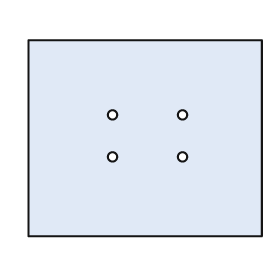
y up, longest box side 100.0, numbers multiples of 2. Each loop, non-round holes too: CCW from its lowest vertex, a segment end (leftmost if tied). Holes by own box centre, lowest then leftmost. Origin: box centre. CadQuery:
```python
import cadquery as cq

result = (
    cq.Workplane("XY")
    .moveTo(-50.0, -42.0)
    .lineTo(50.0, -42.0)
    .lineTo(50.0, 42.0)
    .lineTo(-50.0, 42.0)
    .close()
    .moveTo(-14.0, -8.0)
    .circle(2.0)
    .moveTo(16.0, -8.0)
    .circle(2.0)
    .moveTo(-14.0, 10.0)
    .circle(2.0)
    .moveTo(16.0, 10.0)
    .circle(2.0)
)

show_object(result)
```